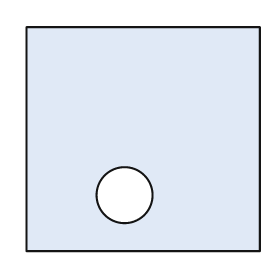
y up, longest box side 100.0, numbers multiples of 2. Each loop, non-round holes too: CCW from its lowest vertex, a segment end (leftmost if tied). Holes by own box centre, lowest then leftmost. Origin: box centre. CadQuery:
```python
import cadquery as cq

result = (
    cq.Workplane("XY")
    .moveTo(-50.0, -48.0)
    .lineTo(50.0, -48.0)
    .lineTo(50.0, 48.0)
    .lineTo(-50.0, 48.0)
    .close()
    .moveTo(-8.0, -24.0)
    .circle(12.0)
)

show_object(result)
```